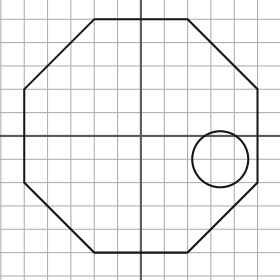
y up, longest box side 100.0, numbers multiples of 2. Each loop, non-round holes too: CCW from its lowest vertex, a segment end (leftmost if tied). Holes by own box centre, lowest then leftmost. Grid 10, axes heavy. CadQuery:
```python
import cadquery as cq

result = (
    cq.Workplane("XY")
    .moveTo(-20.0, -50.0)
    .lineTo(20.0, -50.0)
    .lineTo(50.0, -20.0)
    .lineTo(50.0, 20.0)
    .lineTo(20.0, 50.0)
    .lineTo(-20.0, 50.0)
    .lineTo(-50.0, 20.0)
    .lineTo(-50.0, -20.0)
    .close()
    .moveTo(34.0, -10.0)
    .circle(12.0)
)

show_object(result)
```